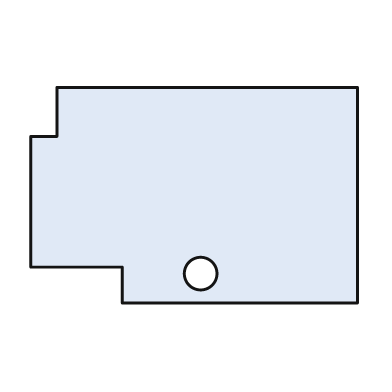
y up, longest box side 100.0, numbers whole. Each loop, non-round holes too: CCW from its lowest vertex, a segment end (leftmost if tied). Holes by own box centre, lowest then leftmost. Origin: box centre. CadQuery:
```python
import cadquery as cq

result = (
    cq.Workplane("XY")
    .moveTo(-22.0, -33.0)
    .lineTo(50.0, -33.0)
    .lineTo(50.0, 33.0)
    .lineTo(-42.0, 33.0)
    .lineTo(-42.0, 18.0)
    .lineTo(-50.0, 18.0)
    .lineTo(-50.0, -22.0)
    .lineTo(-22.0, -22.0)
    .close()
    .moveTo(2.0, -24.0)
    .circle(5.0)
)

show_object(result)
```